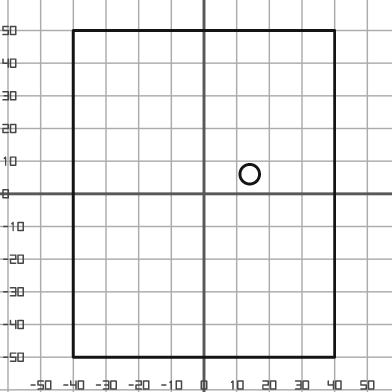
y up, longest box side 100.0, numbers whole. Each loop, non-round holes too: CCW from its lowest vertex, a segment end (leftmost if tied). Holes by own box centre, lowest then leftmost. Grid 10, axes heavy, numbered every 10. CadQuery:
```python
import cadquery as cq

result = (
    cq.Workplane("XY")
    .moveTo(-40.0, -50.0)
    .lineTo(40.0, -50.0)
    .lineTo(40.0, 50.0)
    .lineTo(-40.0, 50.0)
    .close()
    .moveTo(14.0, 6.0)
    .circle(3.0)
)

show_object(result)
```